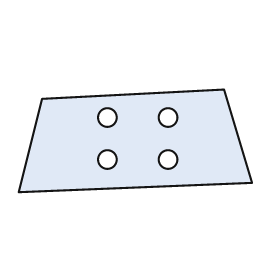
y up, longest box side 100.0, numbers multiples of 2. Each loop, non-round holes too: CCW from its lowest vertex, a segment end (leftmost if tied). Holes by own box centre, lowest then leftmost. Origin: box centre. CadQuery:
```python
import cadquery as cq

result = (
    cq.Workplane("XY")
    .moveTo(-50.0, -22.0)
    .lineTo(50.0, -18.0)
    .lineTo(38.0, 22.0)
    .lineTo(-40.0, 18.0)
    .close()
    .moveTo(-12.0, -8.0)
    .circle(4.0)
    .moveTo(14.0, -8.0)
    .circle(4.0)
    .moveTo(-12.0, 10.0)
    .circle(4.0)
    .moveTo(14.0, 10.0)
    .circle(4.0)
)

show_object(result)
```